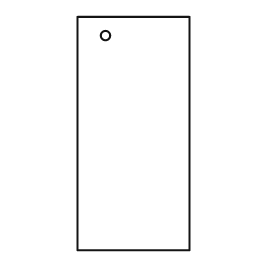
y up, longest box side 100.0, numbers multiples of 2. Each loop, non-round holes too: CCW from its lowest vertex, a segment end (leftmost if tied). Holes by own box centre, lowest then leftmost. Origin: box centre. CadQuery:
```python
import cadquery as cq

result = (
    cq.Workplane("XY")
    .moveTo(-24.0, -50.0)
    .lineTo(24.0, -50.0)
    .lineTo(24.0, 50.0)
    .lineTo(-24.0, 50.0)
    .close()
    .moveTo(-12.0, 42.0)
    .circle(2.0)
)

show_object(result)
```